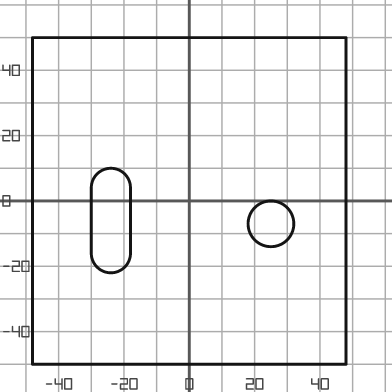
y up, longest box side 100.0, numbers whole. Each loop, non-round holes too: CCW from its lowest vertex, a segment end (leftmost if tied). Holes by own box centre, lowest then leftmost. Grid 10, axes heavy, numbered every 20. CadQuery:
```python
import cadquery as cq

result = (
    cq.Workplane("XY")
    .moveTo(-48.0, -50.0)
    .lineTo(48.0, -50.0)
    .lineTo(48.0, 50.0)
    .lineTo(-48.0, 50.0)
    .close()
    .moveTo(25.0, -7.0)
    .circle(7.0)
    .moveTo(-30.0, -16.0)
    .threePointArc((-24.0, -22.0), (-18.0, -16.0))
    .lineTo(-18.0, 4.0)
    .threePointArc((-24.0, 10.0), (-30.0, 4.0))
    .close()
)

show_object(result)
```